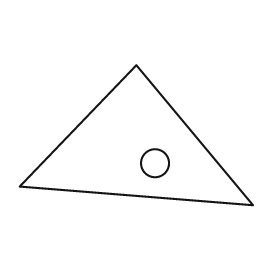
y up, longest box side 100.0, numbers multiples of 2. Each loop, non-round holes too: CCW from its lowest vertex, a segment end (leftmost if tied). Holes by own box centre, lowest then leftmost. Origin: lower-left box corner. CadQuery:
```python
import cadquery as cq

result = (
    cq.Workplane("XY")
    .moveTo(100.0, 0.0)
    .lineTo(50.0, 60.0)
    .lineTo(0.0, 8.0)
    .close()
    .moveTo(58.0, 18.0)
    .circle(6.0)
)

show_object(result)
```